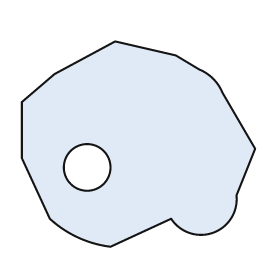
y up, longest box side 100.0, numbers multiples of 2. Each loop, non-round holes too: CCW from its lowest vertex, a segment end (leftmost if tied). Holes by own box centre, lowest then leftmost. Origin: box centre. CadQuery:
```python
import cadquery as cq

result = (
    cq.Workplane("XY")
    .moveTo(-12.0, -44.0)
    .lineTo(14.0, -32.0)
    .threePointArc((32.0, -38.0), (42.0, -22.0))
    .lineTo(50.0, -2.0)
    .lineTo(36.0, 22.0)
    .threePointArc((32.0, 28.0), (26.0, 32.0))
    .lineTo(16.0, 38.0)
    .lineTo(-10.0, 44.0)
    .lineTo(-36.0, 30.0)
    .lineTo(-50.0, 18.0)
    .lineTo(-50.0, -6.0)
    .lineTo(-38.0, -32.0)
    .threePointArc((-26.0, -40.0), (-12.0, -44.0))
    .close()
    .moveTo(-22.0, -10.0)
    .circle(10.0)
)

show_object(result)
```